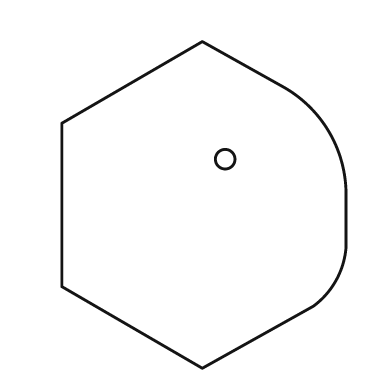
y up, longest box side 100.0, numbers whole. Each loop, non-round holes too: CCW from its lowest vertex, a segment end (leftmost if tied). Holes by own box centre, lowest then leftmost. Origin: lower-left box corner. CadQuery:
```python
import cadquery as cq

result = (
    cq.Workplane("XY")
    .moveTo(43.0, 0.0)
    .lineTo(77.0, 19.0)
    .threePointArc((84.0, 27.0), (87.0, 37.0))
    .lineTo(87.0, 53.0)
    .threePointArc((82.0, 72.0), (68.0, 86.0))
    .lineTo(43.0, 100.0)
    .lineTo(0.0, 75.0)
    .lineTo(0.0, 25.0)
    .close()
    .moveTo(50.0, 64.0)
    .circle(3.0)
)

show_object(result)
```